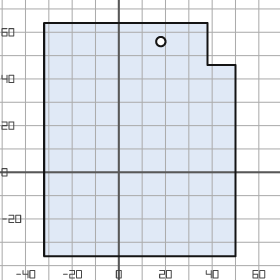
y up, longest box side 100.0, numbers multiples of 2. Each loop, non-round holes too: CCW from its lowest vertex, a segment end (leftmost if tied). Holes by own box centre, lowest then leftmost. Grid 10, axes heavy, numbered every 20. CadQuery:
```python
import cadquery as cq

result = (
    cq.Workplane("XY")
    .moveTo(-32.0, -36.0)
    .lineTo(50.0, -36.0)
    .lineTo(50.0, 46.0)
    .lineTo(38.0, 46.0)
    .lineTo(38.0, 64.0)
    .lineTo(-32.0, 64.0)
    .close()
    .moveTo(18.0, 56.0)
    .circle(2.0)
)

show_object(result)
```